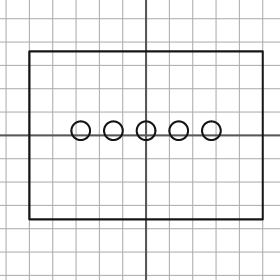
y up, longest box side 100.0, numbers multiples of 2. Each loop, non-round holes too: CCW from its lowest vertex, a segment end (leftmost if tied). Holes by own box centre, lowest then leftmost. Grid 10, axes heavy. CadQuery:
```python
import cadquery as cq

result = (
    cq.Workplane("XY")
    .moveTo(-50.0, -36.0)
    .lineTo(50.0, -36.0)
    .lineTo(50.0, 36.0)
    .lineTo(-50.0, 36.0)
    .close()
    .moveTo(-28.0, 2.0)
    .circle(4.0)
    .moveTo(-14.0, 2.0)
    .circle(4.0)
    .moveTo(0.0, 2.0)
    .circle(4.0)
    .moveTo(14.0, 2.0)
    .circle(4.0)
    .moveTo(28.0, 2.0)
    .circle(4.0)
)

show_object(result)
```